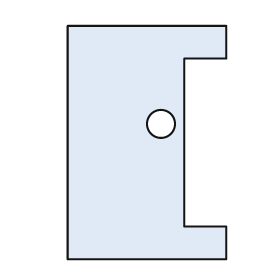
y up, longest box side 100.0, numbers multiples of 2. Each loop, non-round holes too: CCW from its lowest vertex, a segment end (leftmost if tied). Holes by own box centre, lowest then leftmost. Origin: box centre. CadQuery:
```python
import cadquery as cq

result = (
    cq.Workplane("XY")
    .moveTo(-34.0, -50.0)
    .lineTo(34.0, -50.0)
    .lineTo(34.0, -36.0)
    .lineTo(16.0, -36.0)
    .lineTo(16.0, 36.0)
    .lineTo(34.0, 36.0)
    .lineTo(34.0, 50.0)
    .lineTo(-34.0, 50.0)
    .close()
    .moveTo(6.0, 8.0)
    .circle(6.0)
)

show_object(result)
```